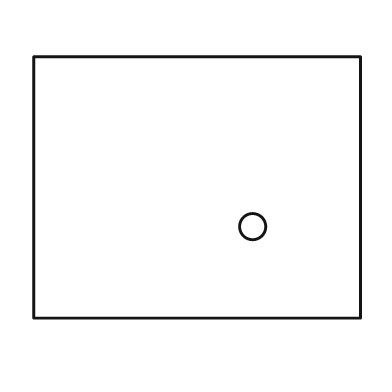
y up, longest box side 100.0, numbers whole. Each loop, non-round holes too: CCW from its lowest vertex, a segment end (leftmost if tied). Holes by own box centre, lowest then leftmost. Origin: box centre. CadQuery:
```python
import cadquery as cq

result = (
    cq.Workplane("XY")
    .moveTo(-50.0, -40.0)
    .lineTo(50.0, -40.0)
    .lineTo(50.0, 40.0)
    .lineTo(-50.0, 40.0)
    .close()
    .moveTo(17.0, -12.0)
    .circle(4.0)
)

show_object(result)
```